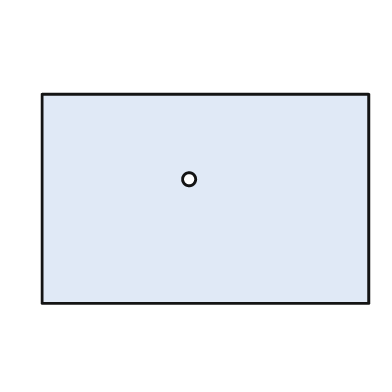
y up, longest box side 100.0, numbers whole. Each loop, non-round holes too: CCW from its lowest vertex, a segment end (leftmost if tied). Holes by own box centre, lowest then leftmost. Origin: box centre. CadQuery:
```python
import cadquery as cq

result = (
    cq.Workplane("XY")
    .moveTo(-50.0, -32.0)
    .lineTo(50.0, -32.0)
    .lineTo(50.0, 32.0)
    .lineTo(-50.0, 32.0)
    .close()
    .moveTo(-5.0, 6.0)
    .circle(2.0)
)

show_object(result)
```